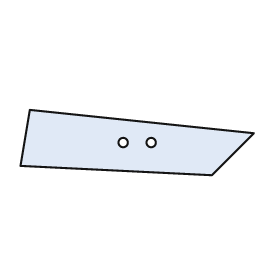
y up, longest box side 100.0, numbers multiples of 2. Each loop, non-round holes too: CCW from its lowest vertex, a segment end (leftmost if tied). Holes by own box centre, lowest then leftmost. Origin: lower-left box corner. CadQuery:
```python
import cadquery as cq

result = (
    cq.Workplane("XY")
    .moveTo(82.0, 0.0)
    .lineTo(100.0, 18.0)
    .lineTo(4.0, 28.0)
    .lineTo(0.0, 4.0)
    .close()
    .moveTo(44.0, 14.0)
    .circle(2.0)
    .moveTo(56.0, 14.0)
    .circle(2.0)
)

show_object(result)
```